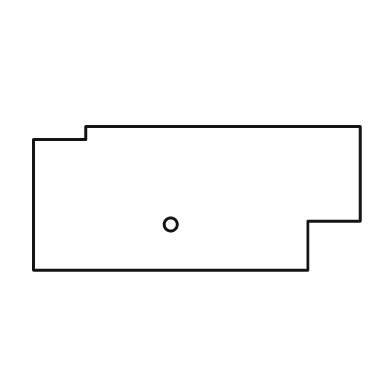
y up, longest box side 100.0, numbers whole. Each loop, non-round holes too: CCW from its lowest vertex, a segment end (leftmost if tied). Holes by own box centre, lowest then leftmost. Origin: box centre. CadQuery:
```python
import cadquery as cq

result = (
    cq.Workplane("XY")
    .moveTo(-50.0, -22.0)
    .lineTo(34.0, -22.0)
    .lineTo(34.0, -7.0)
    .lineTo(50.0, -7.0)
    .lineTo(50.0, 22.0)
    .lineTo(-34.0, 22.0)
    .lineTo(-34.0, 18.0)
    .lineTo(-50.0, 18.0)
    .close()
    .moveTo(-8.0, -8.0)
    .circle(2.0)
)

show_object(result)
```